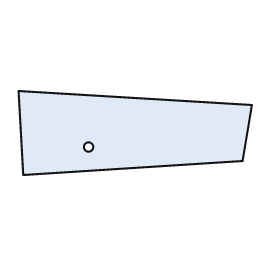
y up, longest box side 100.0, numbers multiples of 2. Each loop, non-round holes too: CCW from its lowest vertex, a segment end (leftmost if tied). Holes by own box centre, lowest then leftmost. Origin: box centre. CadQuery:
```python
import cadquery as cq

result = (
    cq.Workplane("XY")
    .moveTo(-48.0, -18.0)
    .lineTo(46.0, -12.0)
    .lineTo(50.0, 12.0)
    .lineTo(-50.0, 18.0)
    .close()
    .moveTo(-20.0, -6.0)
    .circle(2.0)
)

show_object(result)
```